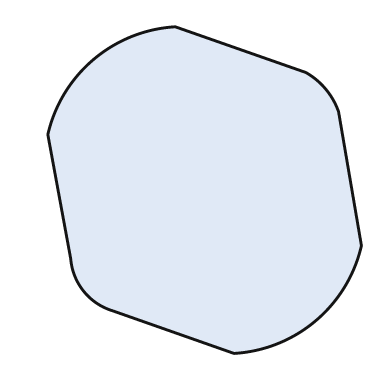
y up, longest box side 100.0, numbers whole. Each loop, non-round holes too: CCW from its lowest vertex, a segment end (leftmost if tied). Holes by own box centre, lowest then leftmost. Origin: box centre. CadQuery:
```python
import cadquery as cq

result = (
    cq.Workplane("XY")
    .moveTo(9.0, -50.0)
    .threePointArc((34.0, -40.0), (48.0, -17.0))
    .lineTo(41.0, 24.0)
    .threePointArc((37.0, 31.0), (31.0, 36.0))
    .lineTo(-9.0, 50.0)
    .threePointArc((-34.0, 40.0), (-48.0, 17.0))
    .lineTo(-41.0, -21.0)
    .threePointArc((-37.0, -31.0), (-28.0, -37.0))
    .close()
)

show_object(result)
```